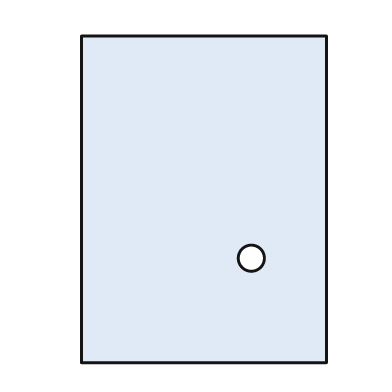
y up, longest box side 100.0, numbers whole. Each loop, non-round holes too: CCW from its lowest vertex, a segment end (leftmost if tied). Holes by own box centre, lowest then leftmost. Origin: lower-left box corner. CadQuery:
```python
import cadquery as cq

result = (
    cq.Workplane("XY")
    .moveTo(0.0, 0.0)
    .lineTo(75.0, 0.0)
    .lineTo(75.0, 100.0)
    .lineTo(0.0, 100.0)
    .close()
    .moveTo(52.0, 32.0)
    .circle(4.0)
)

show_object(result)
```